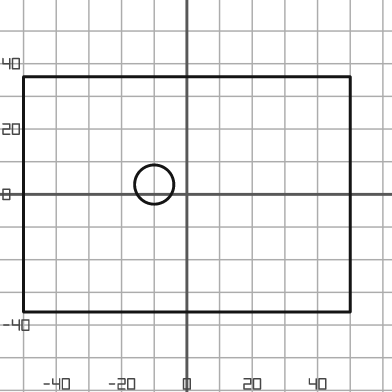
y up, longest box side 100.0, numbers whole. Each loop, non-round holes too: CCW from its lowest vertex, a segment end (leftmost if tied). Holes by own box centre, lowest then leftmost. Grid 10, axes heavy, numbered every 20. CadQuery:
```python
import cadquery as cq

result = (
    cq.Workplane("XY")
    .moveTo(-50.0, -36.0)
    .lineTo(50.0, -36.0)
    .lineTo(50.0, 36.0)
    .lineTo(-50.0, 36.0)
    .close()
    .moveTo(-10.0, 3.0)
    .circle(6.0)
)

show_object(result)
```